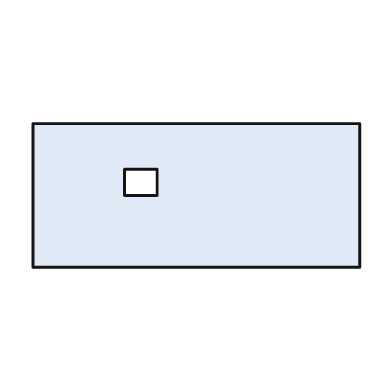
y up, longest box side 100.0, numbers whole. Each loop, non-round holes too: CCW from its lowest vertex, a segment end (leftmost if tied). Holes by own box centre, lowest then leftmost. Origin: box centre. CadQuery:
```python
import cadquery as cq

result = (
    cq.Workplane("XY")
    .moveTo(-50.0, -22.0)
    .lineTo(50.0, -22.0)
    .lineTo(50.0, 22.0)
    .lineTo(-50.0, 22.0)
    .close()
    .moveTo(-22.0, 0.0)
    .lineTo(-12.0, 0.0)
    .lineTo(-12.0, 8.0)
    .lineTo(-22.0, 8.0)
    .close()
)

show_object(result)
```